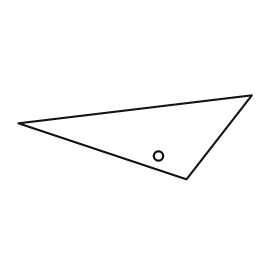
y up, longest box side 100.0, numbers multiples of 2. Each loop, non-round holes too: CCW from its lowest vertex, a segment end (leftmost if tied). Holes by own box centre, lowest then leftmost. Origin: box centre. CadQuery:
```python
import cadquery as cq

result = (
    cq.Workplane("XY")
    .moveTo(22.0, -18.0)
    .lineTo(50.0, 18.0)
    .lineTo(-50.0, 6.0)
    .close()
    .moveTo(10.0, -8.0)
    .circle(2.0)
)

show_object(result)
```